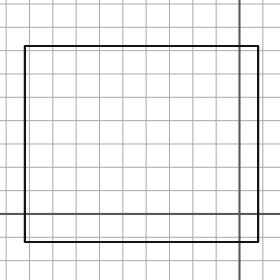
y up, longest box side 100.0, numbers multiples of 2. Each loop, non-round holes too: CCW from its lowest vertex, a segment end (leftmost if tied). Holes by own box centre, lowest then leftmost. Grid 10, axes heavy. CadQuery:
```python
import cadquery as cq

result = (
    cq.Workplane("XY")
    .moveTo(-92.0, -12.0)
    .lineTo(8.0, -12.0)
    .lineTo(8.0, 72.0)
    .lineTo(-92.0, 72.0)
    .close()
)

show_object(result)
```